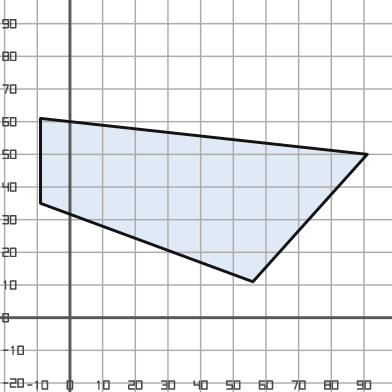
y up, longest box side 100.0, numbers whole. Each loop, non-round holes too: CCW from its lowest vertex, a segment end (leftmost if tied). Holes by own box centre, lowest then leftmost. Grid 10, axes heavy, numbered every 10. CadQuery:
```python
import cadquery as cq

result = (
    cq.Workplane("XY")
    .moveTo(56.0, 11.0)
    .lineTo(91.0, 50.0)
    .lineTo(-9.0, 61.0)
    .lineTo(-9.0, 35.0)
    .close()
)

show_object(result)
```